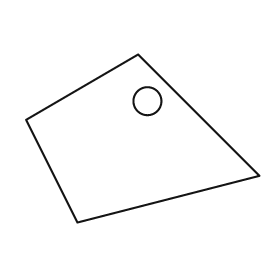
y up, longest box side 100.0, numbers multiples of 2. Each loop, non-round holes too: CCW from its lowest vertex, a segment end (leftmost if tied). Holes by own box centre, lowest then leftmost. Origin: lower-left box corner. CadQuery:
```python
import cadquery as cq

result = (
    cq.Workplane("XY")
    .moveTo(22.0, 0.0)
    .lineTo(100.0, 20.0)
    .lineTo(48.0, 72.0)
    .lineTo(0.0, 44.0)
    .close()
    .moveTo(52.0, 52.0)
    .circle(6.0)
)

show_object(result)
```